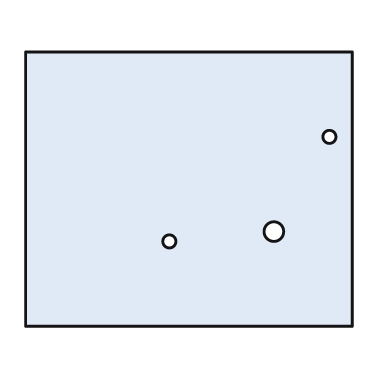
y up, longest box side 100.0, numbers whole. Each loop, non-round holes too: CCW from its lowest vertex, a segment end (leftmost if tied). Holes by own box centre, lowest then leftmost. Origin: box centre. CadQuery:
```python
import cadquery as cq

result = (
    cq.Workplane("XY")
    .moveTo(-50.0, -42.0)
    .lineTo(50.0, -42.0)
    .lineTo(50.0, 42.0)
    .lineTo(-50.0, 42.0)
    .close()
    .moveTo(-6.0, -16.0)
    .circle(2.0)
    .moveTo(26.0, -13.0)
    .circle(3.0)
    .moveTo(43.0, 16.0)
    .circle(2.0)
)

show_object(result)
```